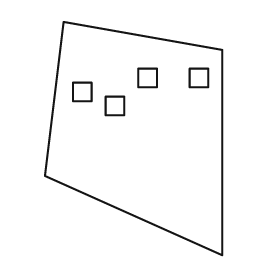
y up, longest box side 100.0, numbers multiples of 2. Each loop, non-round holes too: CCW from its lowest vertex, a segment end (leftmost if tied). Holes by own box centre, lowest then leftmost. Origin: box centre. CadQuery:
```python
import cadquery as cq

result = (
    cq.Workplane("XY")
    .moveTo(38.0, -50.0)
    .lineTo(38.0, 38.0)
    .lineTo(-30.0, 50.0)
    .lineTo(-38.0, -16.0)
    .close()
    .moveTo(-12.0, 10.0)
    .lineTo(-4.0, 10.0)
    .lineTo(-4.0, 18.0)
    .lineTo(-12.0, 18.0)
    .close()
    .moveTo(-26.0, 16.0)
    .lineTo(-18.0, 16.0)
    .lineTo(-18.0, 24.0)
    .lineTo(-26.0, 24.0)
    .close()
    .moveTo(2.0, 22.0)
    .lineTo(10.0, 22.0)
    .lineTo(10.0, 30.0)
    .lineTo(2.0, 30.0)
    .close()
    .moveTo(24.0, 22.0)
    .lineTo(32.0, 22.0)
    .lineTo(32.0, 30.0)
    .lineTo(24.0, 30.0)
    .close()
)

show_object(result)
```